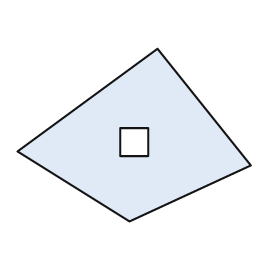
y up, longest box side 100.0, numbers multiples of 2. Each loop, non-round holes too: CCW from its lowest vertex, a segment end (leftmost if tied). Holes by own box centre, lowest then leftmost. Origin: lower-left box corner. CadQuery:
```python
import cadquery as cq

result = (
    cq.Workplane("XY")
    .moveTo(48.0, 0.0)
    .lineTo(100.0, 24.0)
    .lineTo(60.0, 74.0)
    .lineTo(0.0, 30.0)
    .close()
    .moveTo(44.0, 28.0)
    .lineTo(56.0, 28.0)
    .lineTo(56.0, 40.0)
    .lineTo(44.0, 40.0)
    .close()
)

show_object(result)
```